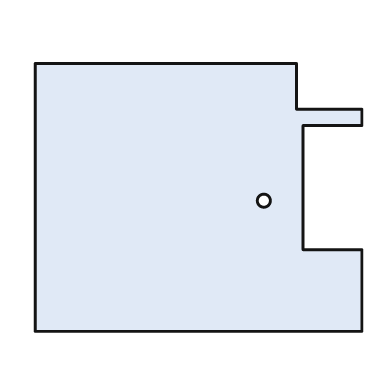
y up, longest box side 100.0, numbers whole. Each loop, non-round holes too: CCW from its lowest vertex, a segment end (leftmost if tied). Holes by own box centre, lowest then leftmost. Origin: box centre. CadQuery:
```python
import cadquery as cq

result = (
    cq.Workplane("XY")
    .moveTo(-50.0, -41.0)
    .lineTo(50.0, -41.0)
    .lineTo(50.0, -16.0)
    .lineTo(32.0, -16.0)
    .lineTo(32.0, 22.0)
    .lineTo(50.0, 22.0)
    .lineTo(50.0, 27.0)
    .lineTo(30.0, 27.0)
    .lineTo(30.0, 41.0)
    .lineTo(-50.0, 41.0)
    .close()
    .moveTo(20.0, -1.0)
    .circle(2.0)
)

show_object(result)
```